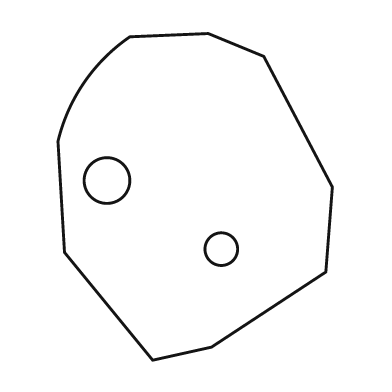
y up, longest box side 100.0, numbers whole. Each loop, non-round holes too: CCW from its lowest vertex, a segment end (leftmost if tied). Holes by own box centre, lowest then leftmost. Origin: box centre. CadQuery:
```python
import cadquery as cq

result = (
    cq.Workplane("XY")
    .moveTo(-13.0, -50.0)
    .lineTo(5.0, -46.0)
    .lineTo(40.0, -23.0)
    .lineTo(42.0, 3.0)
    .lineTo(21.0, 43.0)
    .lineTo(4.0, 50.0)
    .lineTo(-20.0, 49.0)
    .threePointArc((-34.0, 35.0), (-42.0, 17.0))
    .lineTo(-40.0, -17.0)
    .close()
    .moveTo(8.0, -16.0)
    .circle(5.0)
    .moveTo(-27.0, 5.0)
    .circle(7.0)
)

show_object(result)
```